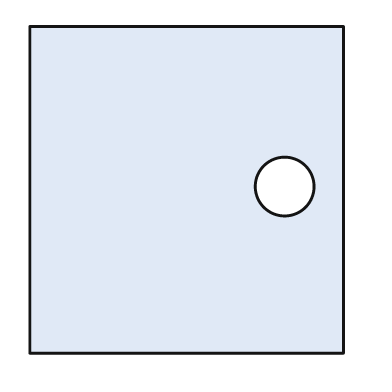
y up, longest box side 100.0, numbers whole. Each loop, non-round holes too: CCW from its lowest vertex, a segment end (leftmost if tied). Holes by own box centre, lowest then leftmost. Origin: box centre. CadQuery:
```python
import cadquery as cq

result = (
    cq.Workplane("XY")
    .moveTo(-48.0, -50.0)
    .lineTo(48.0, -50.0)
    .lineTo(48.0, 50.0)
    .lineTo(-48.0, 50.0)
    .close()
    .moveTo(30.0, 1.0)
    .circle(9.0)
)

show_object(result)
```